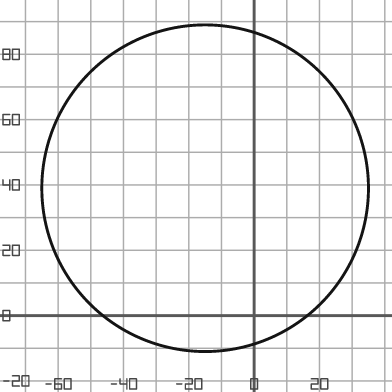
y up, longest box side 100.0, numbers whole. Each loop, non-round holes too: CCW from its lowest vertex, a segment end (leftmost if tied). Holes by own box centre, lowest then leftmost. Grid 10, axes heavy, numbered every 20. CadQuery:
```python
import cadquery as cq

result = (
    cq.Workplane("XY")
    .moveTo(-15.0, 39.0)
    .circle(50.0)
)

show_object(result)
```